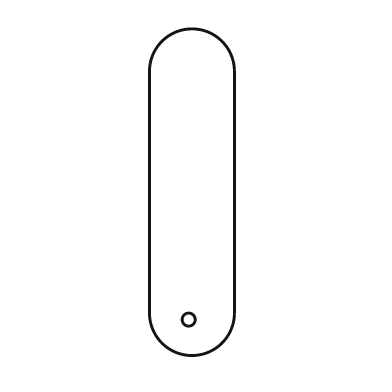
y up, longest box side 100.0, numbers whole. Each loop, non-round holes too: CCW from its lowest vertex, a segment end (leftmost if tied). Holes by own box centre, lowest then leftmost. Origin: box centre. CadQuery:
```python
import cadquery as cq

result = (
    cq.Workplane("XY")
    .moveTo(-13.0, -37.0)
    .threePointArc((0.0, -50.0), (13.0, -37.0))
    .lineTo(13.0, 37.0)
    .threePointArc((0.0, 50.0), (-13.0, 37.0))
    .close()
    .moveTo(-1.0, -39.0)
    .circle(2.0)
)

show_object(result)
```